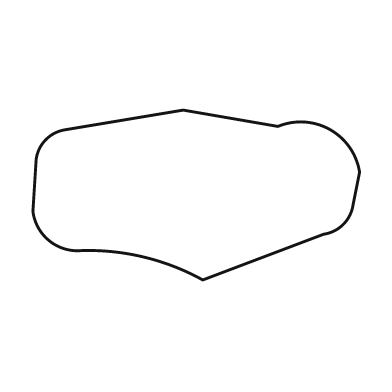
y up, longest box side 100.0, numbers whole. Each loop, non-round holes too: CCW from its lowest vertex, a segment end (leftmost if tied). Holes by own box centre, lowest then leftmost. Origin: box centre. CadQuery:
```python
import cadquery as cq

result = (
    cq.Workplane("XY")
    .moveTo(2.0, -26.0)
    .lineTo(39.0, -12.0)
    .threePointArc((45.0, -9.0), (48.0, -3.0))
    .lineTo(50.0, 7.0)
    .threePointArc((41.0, 20.0), (25.0, 21.0))
    .lineTo(-4.0, 26.0)
    .lineTo(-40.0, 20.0)
    .threePointArc((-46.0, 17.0), (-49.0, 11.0))
    .lineTo(-50.0, -5.0)
    .threePointArc((-45.0, -14.0), (-35.0, -17.0))
    .threePointArc((-16.0, -19.0), (2.0, -26.0))
    .close()
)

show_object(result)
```